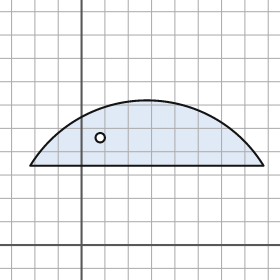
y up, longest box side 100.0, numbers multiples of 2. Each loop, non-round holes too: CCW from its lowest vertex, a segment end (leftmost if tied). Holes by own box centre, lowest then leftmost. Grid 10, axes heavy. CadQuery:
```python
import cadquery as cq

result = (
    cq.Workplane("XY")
    .moveTo(-22.0, 34.0)
    .lineTo(78.0, 34.0)
    .threePointArc((28.0, 62.0), (-22.0, 34.0))
    .close()
    .moveTo(8.0, 46.0)
    .circle(2.0)
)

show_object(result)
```